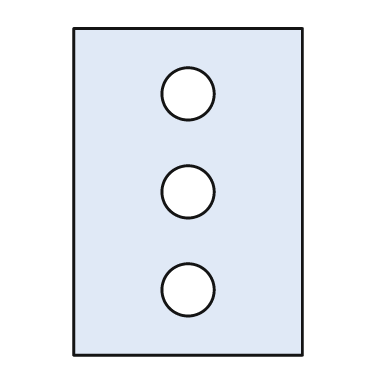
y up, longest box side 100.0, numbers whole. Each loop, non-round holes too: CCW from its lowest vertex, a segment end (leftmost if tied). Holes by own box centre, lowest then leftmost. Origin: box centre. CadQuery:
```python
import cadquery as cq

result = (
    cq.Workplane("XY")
    .moveTo(-35.0, -50.0)
    .lineTo(35.0, -50.0)
    .lineTo(35.0, 50.0)
    .lineTo(-35.0, 50.0)
    .close()
    .moveTo(0.0, -30.0)
    .circle(8.0)
    .moveTo(0.0, 0.0)
    .circle(8.0)
    .moveTo(0.0, 30.0)
    .circle(8.0)
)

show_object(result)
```